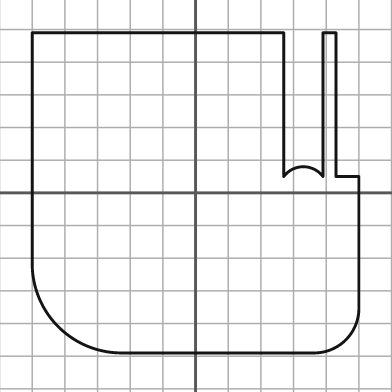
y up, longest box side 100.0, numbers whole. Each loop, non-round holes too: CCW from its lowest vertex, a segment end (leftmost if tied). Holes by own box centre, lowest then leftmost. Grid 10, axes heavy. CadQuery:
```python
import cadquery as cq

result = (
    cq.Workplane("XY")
    .moveTo(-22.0, -49.0)
    .lineTo(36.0, -49.0)
    .threePointArc((46.0, -45.0), (50.0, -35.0))
    .lineTo(50.0, 5.0)
    .lineTo(43.0, 5.0)
    .lineTo(43.0, 49.0)
    .lineTo(39.0, 49.0)
    .lineTo(39.0, 5.0)
    .threePointArc((33.0, 8.0), (27.0, 5.0))
    .lineTo(27.0, 49.0)
    .lineTo(-50.0, 49.0)
    .lineTo(-50.0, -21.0)
    .threePointArc((-42.0, -41.0), (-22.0, -49.0))
    .close()
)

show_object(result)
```